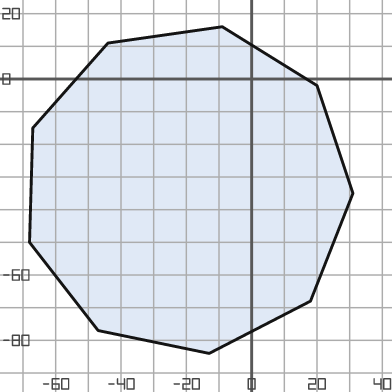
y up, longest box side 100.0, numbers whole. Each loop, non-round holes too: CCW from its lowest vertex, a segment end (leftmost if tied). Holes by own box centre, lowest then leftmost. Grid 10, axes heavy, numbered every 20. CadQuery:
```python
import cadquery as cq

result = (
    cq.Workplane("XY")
    .moveTo(-13.0, -84.0)
    .lineTo(18.0, -68.0)
    .lineTo(31.0, -35.0)
    .lineTo(20.0, -2.0)
    .lineTo(-9.0, 16.0)
    .lineTo(-44.0, 11.0)
    .lineTo(-67.0, -15.0)
    .lineTo(-68.0, -50.0)
    .lineTo(-47.0, -77.0)
    .close()
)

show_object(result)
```